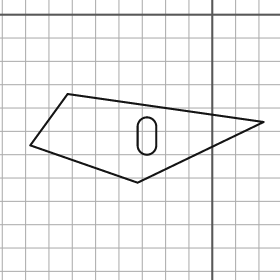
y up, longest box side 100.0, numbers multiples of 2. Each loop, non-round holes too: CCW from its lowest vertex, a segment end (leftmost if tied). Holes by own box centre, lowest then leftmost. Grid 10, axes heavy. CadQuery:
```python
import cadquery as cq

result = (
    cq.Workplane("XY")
    .moveTo(-32.0, -72.0)
    .lineTo(22.0, -46.0)
    .lineTo(-62.0, -34.0)
    .lineTo(-78.0, -56.0)
    .close()
    .moveTo(-32.0, -56.0)
    .threePointArc((-28.0, -60.0), (-24.0, -56.0))
    .lineTo(-24.0, -48.0)
    .threePointArc((-28.0, -44.0), (-32.0, -48.0))
    .close()
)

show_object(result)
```